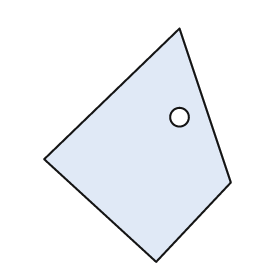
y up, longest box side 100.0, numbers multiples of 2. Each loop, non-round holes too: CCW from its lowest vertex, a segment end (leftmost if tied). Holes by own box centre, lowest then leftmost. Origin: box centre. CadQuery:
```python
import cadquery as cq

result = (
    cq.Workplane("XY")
    .moveTo(8.0, -50.0)
    .lineTo(40.0, -16.0)
    .lineTo(18.0, 50.0)
    .lineTo(-40.0, -6.0)
    .close()
    .moveTo(18.0, 12.0)
    .circle(4.0)
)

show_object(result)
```